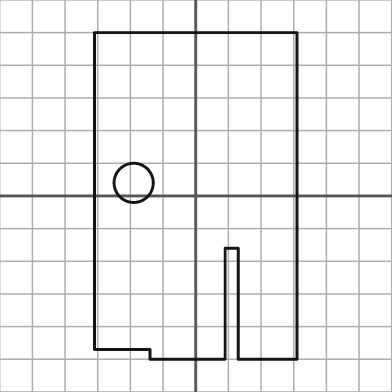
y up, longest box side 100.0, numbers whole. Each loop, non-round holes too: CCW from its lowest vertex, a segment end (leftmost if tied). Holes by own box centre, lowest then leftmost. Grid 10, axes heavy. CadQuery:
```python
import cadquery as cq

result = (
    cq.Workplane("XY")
    .moveTo(-14.0, -50.0)
    .lineTo(9.0, -50.0)
    .lineTo(9.0, -16.0)
    .lineTo(13.0, -16.0)
    .lineTo(13.0, -50.0)
    .lineTo(31.0, -50.0)
    .lineTo(31.0, 50.0)
    .lineTo(-31.0, 50.0)
    .lineTo(-31.0, -47.0)
    .lineTo(-14.0, -47.0)
    .close()
    .moveTo(-19.0, 4.0)
    .circle(6.0)
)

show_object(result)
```